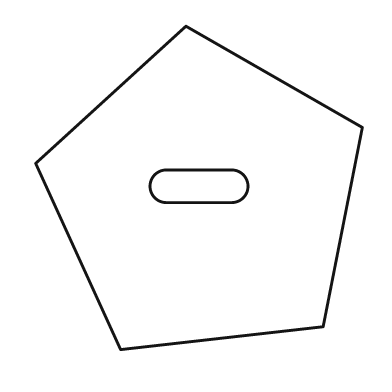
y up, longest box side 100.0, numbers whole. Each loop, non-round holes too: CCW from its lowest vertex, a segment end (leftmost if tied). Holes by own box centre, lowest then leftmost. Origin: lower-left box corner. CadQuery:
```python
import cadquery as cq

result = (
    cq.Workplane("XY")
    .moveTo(26.0, 0.0)
    .lineTo(88.0, 7.0)
    .lineTo(100.0, 68.0)
    .lineTo(46.0, 99.0)
    .lineTo(0.0, 57.0)
    .close()
    .moveTo(40.0, 45.0)
    .lineTo(60.0, 45.0)
    .threePointArc((65.0, 50.0), (60.0, 55.0))
    .lineTo(40.0, 55.0)
    .threePointArc((35.0, 50.0), (40.0, 45.0))
    .close()
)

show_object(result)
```